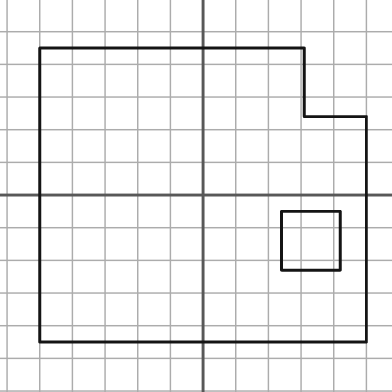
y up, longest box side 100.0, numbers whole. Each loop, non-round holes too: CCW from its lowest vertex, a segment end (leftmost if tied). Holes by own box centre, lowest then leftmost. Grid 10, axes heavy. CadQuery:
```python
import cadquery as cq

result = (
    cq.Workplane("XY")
    .moveTo(-50.0, -45.0)
    .lineTo(50.0, -45.0)
    .lineTo(50.0, 24.0)
    .lineTo(31.0, 24.0)
    .lineTo(31.0, 45.0)
    .lineTo(-50.0, 45.0)
    .close()
    .moveTo(24.0, -23.0)
    .lineTo(42.0, -23.0)
    .lineTo(42.0, -5.0)
    .lineTo(24.0, -5.0)
    .close()
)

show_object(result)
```